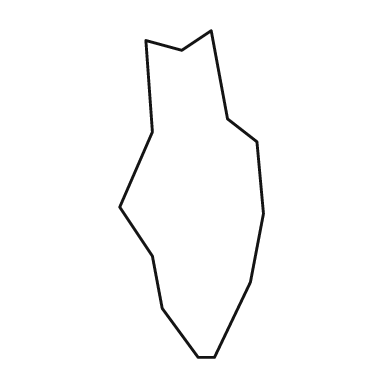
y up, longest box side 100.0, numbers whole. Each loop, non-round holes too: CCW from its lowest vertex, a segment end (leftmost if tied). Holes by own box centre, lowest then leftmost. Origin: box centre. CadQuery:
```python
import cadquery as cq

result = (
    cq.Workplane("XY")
    .moveTo(2.0, -50.0)
    .lineTo(7.0, -50.0)
    .lineTo(18.0, -27.0)
    .lineTo(22.0, -6.0)
    .lineTo(20.0, 16.0)
    .lineTo(11.0, 23.0)
    .lineTo(6.0, 50.0)
    .lineTo(-3.0, 44.0)
    .lineTo(-14.0, 47.0)
    .lineTo(-12.0, 19.0)
    .lineTo(-22.0, -4.0)
    .lineTo(-12.0, -19.0)
    .lineTo(-9.0, -35.0)
    .close()
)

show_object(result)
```